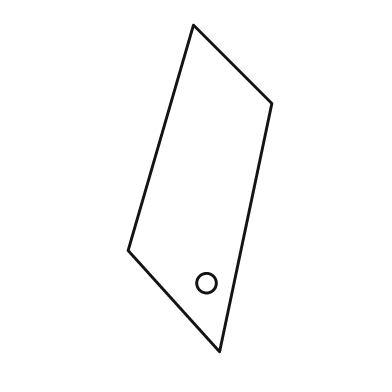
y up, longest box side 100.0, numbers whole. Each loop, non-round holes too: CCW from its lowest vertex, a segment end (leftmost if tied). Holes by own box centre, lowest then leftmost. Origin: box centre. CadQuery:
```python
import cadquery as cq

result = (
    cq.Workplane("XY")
    .moveTo(6.0, -50.0)
    .lineTo(22.0, 26.0)
    .lineTo(-2.0, 50.0)
    .lineTo(-22.0, -19.0)
    .close()
    .moveTo(2.0, -29.0)
    .circle(3.0)
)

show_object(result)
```